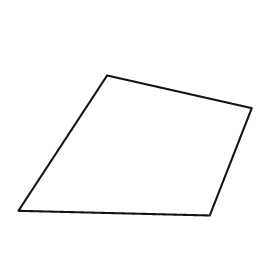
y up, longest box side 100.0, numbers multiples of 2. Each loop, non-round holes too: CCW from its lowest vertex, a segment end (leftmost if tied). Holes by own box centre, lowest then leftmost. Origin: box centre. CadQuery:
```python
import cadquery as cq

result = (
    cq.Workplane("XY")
    .moveTo(32.0, -30.0)
    .lineTo(50.0, 16.0)
    .lineTo(-12.0, 30.0)
    .lineTo(-50.0, -28.0)
    .close()
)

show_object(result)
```